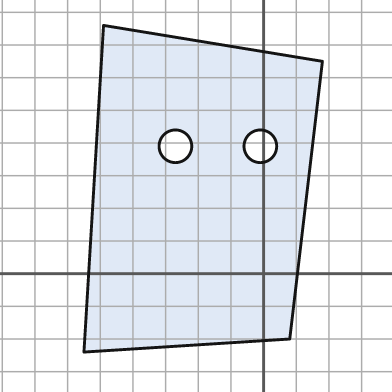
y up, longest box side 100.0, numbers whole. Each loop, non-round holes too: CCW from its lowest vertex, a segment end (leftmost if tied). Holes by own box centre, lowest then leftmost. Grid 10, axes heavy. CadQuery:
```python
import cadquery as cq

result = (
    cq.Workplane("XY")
    .moveTo(-55.0, -24.0)
    .lineTo(8.0, -20.0)
    .lineTo(18.0, 65.0)
    .lineTo(-49.0, 76.0)
    .close()
    .moveTo(-27.0, 39.0)
    .circle(5.0)
    .moveTo(-1.0, 39.0)
    .circle(5.0)
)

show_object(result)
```